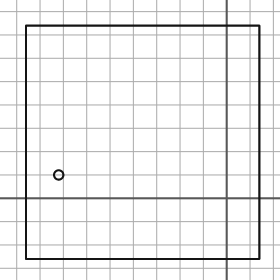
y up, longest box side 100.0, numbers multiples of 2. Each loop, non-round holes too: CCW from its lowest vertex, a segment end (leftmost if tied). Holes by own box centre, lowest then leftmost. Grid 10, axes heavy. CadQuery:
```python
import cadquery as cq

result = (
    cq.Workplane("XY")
    .moveTo(-86.0, -26.0)
    .lineTo(14.0, -26.0)
    .lineTo(14.0, 74.0)
    .lineTo(-86.0, 74.0)
    .close()
    .moveTo(-72.0, 10.0)
    .circle(2.0)
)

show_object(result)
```